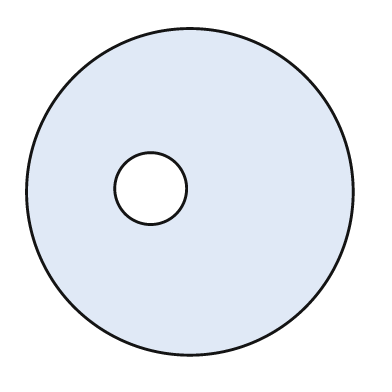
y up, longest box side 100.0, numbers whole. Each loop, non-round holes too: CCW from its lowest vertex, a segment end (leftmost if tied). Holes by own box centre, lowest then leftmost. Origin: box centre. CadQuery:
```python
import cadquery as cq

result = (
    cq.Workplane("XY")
    .moveTo(0.0, 0.0)
    .circle(50.0)
    .moveTo(-12.0, 1.0)
    .circle(11.0)
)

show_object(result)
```